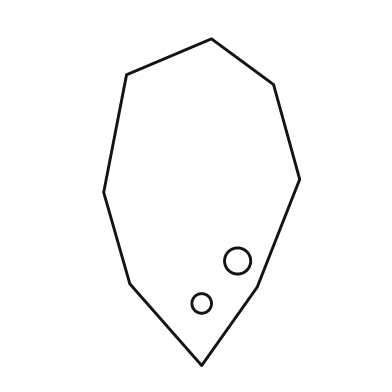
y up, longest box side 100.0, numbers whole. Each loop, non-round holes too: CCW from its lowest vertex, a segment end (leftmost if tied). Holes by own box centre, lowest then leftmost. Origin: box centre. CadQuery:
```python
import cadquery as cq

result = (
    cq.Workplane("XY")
    .moveTo(0.0, -50.0)
    .lineTo(17.0, -26.0)
    .lineTo(30.0, 7.0)
    .lineTo(22.0, 36.0)
    .lineTo(3.0, 50.0)
    .lineTo(-23.0, 39.0)
    .lineTo(-30.0, 3.0)
    .lineTo(-22.0, -25.0)
    .close()
    .moveTo(0.0, -31.0)
    .circle(3.0)
    .moveTo(11.0, -18.0)
    .circle(4.0)
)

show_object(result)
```